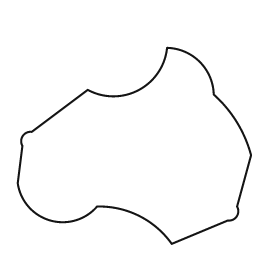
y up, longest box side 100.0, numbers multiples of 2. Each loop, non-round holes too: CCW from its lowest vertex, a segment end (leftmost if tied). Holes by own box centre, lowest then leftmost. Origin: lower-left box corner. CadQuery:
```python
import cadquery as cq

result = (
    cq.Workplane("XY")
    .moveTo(66.0, 0.0)
    .lineTo(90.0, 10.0)
    .threePointArc((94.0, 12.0), (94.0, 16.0))
    .lineTo(100.0, 38.0)
    .threePointArc((94.0, 52.0), (84.0, 64.0))
    .threePointArc((78.0, 78.0), (64.0, 84.0))
    .threePointArc((52.0, 66.0), (30.0, 66.0))
    .lineTo(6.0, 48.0)
    .threePointArc((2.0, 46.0), (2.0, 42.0))
    .lineTo(0.0, 26.0)
    .threePointArc((14.0, 10.0), (34.0, 16.0))
    .threePointArc((52.0, 12.0), (66.0, 0.0))
    .close()
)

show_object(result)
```